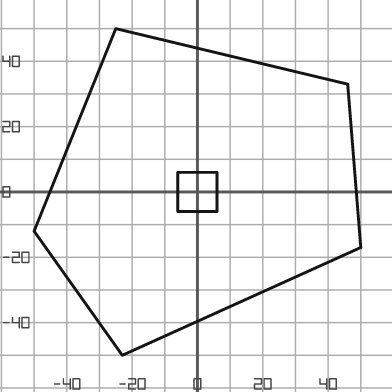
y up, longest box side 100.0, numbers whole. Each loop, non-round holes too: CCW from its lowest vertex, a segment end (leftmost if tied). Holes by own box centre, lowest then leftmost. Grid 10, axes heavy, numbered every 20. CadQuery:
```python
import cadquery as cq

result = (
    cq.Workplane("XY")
    .moveTo(-23.0, -50.0)
    .lineTo(50.0, -17.0)
    .lineTo(46.0, 33.0)
    .lineTo(-25.0, 50.0)
    .lineTo(-50.0, -12.0)
    .close()
    .moveTo(-6.0, -6.0)
    .lineTo(6.0, -6.0)
    .lineTo(6.0, 6.0)
    .lineTo(-6.0, 6.0)
    .close()
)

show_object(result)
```